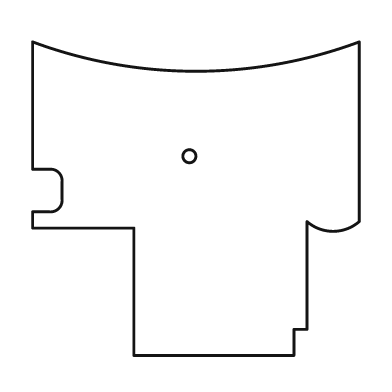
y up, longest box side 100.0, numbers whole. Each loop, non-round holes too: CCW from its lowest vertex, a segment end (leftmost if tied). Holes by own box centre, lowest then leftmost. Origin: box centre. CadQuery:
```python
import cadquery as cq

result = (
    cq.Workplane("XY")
    .moveTo(-19.0, -48.0)
    .lineTo(30.0, -48.0)
    .lineTo(30.0, -40.0)
    .lineTo(34.0, -40.0)
    .lineTo(34.0, -7.0)
    .threePointArc((42.0, -10.0), (50.0, -7.0))
    .lineTo(50.0, 48.0)
    .threePointArc((0.0, 39.0), (-50.0, 48.0))
    .lineTo(-50.0, 9.0)
    .lineTo(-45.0, 9.0)
    .threePointArc((-42.0, 8.0), (-41.0, 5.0))
    .lineTo(-41.0, 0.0)
    .threePointArc((-42.0, -3.0), (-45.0, -4.0))
    .lineTo(-50.0, -4.0)
    .lineTo(-50.0, -9.0)
    .lineTo(-19.0, -9.0)
    .close()
    .moveTo(-2.0, 13.0)
    .circle(2.0)
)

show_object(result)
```